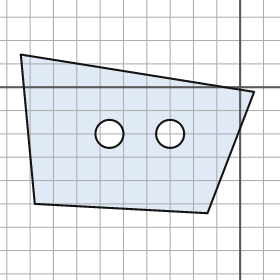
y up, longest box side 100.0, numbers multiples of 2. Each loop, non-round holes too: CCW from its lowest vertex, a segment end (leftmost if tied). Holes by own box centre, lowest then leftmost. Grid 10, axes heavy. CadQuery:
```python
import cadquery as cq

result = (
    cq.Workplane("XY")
    .moveTo(-14.0, -54.0)
    .lineTo(6.0, -2.0)
    .lineTo(-94.0, 14.0)
    .lineTo(-88.0, -50.0)
    .close()
    .moveTo(-56.0, -20.0)
    .circle(6.0)
    .moveTo(-30.0, -20.0)
    .circle(6.0)
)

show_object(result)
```